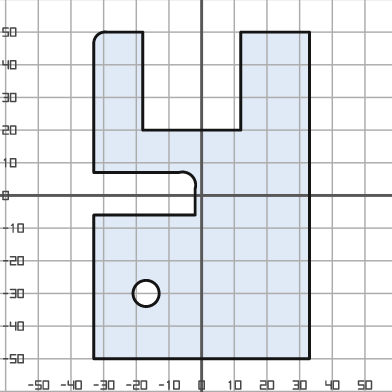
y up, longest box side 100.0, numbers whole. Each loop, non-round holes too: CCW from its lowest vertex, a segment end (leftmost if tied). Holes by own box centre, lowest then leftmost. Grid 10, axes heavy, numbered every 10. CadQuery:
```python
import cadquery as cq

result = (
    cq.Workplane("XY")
    .moveTo(-33.0, -50.0)
    .lineTo(33.0, -50.0)
    .lineTo(33.0, 50.0)
    .lineTo(12.0, 50.0)
    .lineTo(12.0, 20.0)
    .lineTo(-18.0, 20.0)
    .lineTo(-18.0, 50.0)
    .lineTo(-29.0, 50.0)
    .threePointArc((-32.0, 49.0), (-33.0, 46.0))
    .lineTo(-33.0, 7.0)
    .lineTo(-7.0, 7.0)
    .threePointArc((-3.0, 6.0), (-2.0, 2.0))
    .lineTo(-2.0, -6.0)
    .lineTo(-33.0, -6.0)
    .close()
    .moveTo(-17.0, -30.0)
    .circle(4.0)
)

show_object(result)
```